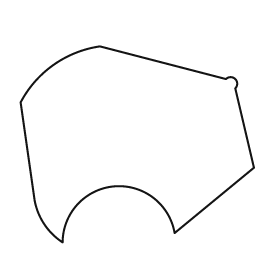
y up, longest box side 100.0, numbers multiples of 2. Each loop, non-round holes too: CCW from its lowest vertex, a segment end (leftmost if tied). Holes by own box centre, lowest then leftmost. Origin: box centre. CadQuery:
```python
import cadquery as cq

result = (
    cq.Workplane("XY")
    .moveTo(-32.0, -42.0)
    .threePointArc((-10.0, -18.0), (16.0, -38.0))
    .lineTo(50.0, -10.0)
    .lineTo(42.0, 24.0)
    .threePointArc((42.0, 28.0), (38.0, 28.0))
    .lineTo(-16.0, 42.0)
    .threePointArc((-36.0, 34.0), (-50.0, 18.0))
    .lineTo(-44.0, -24.0)
    .threePointArc((-40.0, -34.0), (-32.0, -42.0))
    .close()
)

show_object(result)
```